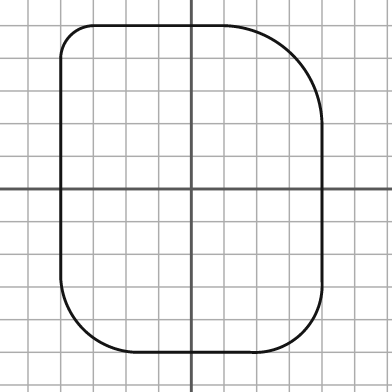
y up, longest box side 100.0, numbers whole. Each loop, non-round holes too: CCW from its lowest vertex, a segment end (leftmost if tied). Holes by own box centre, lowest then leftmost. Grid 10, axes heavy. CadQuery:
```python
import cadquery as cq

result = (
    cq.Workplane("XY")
    .moveTo(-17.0, -50.0)
    .lineTo(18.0, -50.0)
    .threePointArc((34.0, -44.0), (40.0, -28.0))
    .lineTo(40.0, 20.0)
    .threePointArc((31.0, 41.0), (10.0, 50.0))
    .lineTo(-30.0, 50.0)
    .threePointArc((-37.0, 47.0), (-40.0, 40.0))
    .lineTo(-40.0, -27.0)
    .threePointArc((-33.0, -43.0), (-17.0, -50.0))
    .close()
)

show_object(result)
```